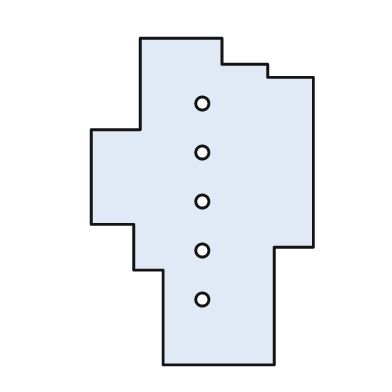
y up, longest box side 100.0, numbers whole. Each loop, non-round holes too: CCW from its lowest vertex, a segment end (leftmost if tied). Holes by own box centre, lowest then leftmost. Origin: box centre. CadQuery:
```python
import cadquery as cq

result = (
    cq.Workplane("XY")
    .moveTo(-12.0, -50.0)
    .lineTo(22.0, -50.0)
    .lineTo(22.0, -14.0)
    .lineTo(34.0, -14.0)
    .lineTo(34.0, 38.0)
    .lineTo(20.0, 38.0)
    .lineTo(20.0, 42.0)
    .lineTo(6.0, 42.0)
    .lineTo(6.0, 50.0)
    .lineTo(-19.0, 50.0)
    .lineTo(-19.0, 22.0)
    .lineTo(-34.0, 22.0)
    .lineTo(-34.0, -7.0)
    .lineTo(-21.0, -7.0)
    .lineTo(-21.0, -21.0)
    .lineTo(-12.0, -21.0)
    .close()
    .moveTo(0.0, -30.0)
    .circle(2.0)
    .moveTo(0.0, -15.0)
    .circle(2.0)
    .moveTo(0.0, 0.0)
    .circle(2.0)
    .moveTo(0.0, 15.0)
    .circle(2.0)
    .moveTo(0.0, 30.0)
    .circle(2.0)
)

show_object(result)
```